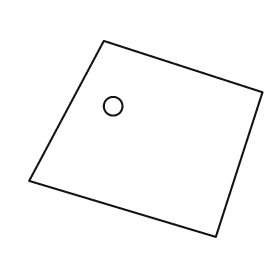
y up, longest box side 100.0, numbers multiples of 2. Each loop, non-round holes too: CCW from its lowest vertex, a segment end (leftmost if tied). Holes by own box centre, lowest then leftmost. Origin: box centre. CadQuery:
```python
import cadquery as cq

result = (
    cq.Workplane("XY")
    .moveTo(30.0, -42.0)
    .lineTo(50.0, 20.0)
    .lineTo(-18.0, 42.0)
    .lineTo(-50.0, -18.0)
    .close()
    .moveTo(-14.0, 14.0)
    .circle(4.0)
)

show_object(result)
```